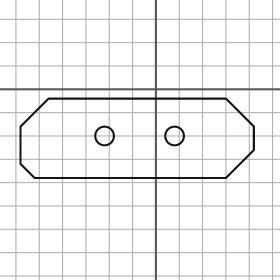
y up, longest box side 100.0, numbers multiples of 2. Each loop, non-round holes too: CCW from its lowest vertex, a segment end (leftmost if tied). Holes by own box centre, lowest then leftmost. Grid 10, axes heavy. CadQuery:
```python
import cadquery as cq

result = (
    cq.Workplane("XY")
    .moveTo(-52.0, -38.0)
    .lineTo(30.0, -38.0)
    .lineTo(42.0, -26.0)
    .lineTo(42.0, -16.0)
    .lineTo(30.0, -4.0)
    .lineTo(-46.0, -4.0)
    .lineTo(-58.0, -16.0)
    .lineTo(-58.0, -32.0)
    .close()
    .moveTo(-22.0, -20.0)
    .circle(4.0)
    .moveTo(8.0, -20.0)
    .circle(4.0)
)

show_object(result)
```